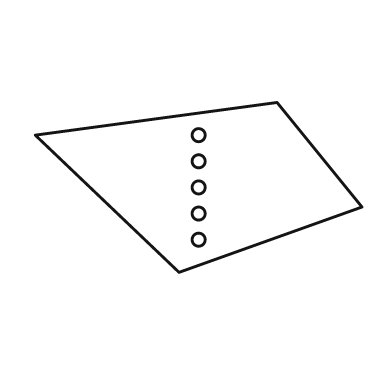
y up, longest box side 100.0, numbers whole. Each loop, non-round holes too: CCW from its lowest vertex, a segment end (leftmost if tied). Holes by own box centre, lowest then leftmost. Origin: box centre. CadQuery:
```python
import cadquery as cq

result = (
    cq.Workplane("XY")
    .moveTo(-6.0, -26.0)
    .lineTo(50.0, -6.0)
    .lineTo(24.0, 26.0)
    .lineTo(-50.0, 16.0)
    .close()
    .moveTo(0.0, -16.0)
    .circle(2.0)
    .moveTo(0.0, -8.0)
    .circle(2.0)
    .moveTo(0.0, 0.0)
    .circle(2.0)
    .moveTo(0.0, 8.0)
    .circle(2.0)
    .moveTo(0.0, 16.0)
    .circle(2.0)
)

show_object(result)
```